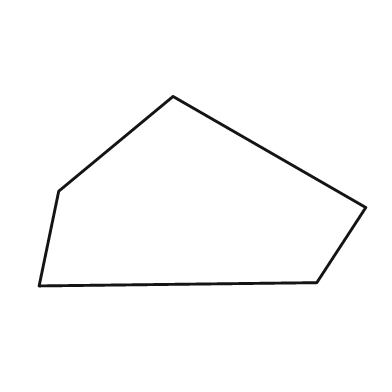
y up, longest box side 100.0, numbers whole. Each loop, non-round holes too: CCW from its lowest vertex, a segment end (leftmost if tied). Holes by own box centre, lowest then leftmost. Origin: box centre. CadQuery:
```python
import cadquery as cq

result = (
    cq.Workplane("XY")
    .moveTo(-50.0, -29.0)
    .lineTo(35.0, -28.0)
    .lineTo(50.0, -5.0)
    .lineTo(-9.0, 29.0)
    .lineTo(-44.0, 0.0)
    .close()
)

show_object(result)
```